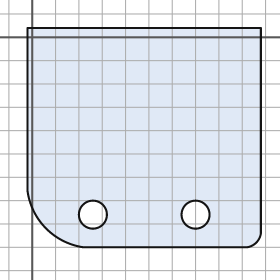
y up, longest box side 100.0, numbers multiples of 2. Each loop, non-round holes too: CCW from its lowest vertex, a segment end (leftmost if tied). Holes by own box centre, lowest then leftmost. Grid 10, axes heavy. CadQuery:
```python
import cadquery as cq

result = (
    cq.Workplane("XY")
    .moveTo(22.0, -90.0)
    .lineTo(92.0, -90.0)
    .threePointArc((96.0, -88.0), (98.0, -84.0))
    .lineTo(98.0, 4.0)
    .lineTo(-2.0, 4.0)
    .lineTo(-2.0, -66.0)
    .threePointArc((6.0, -82.0), (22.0, -90.0))
    .close()
    .moveTo(26.0, -76.0)
    .circle(6.0)
    .moveTo(70.0, -76.0)
    .circle(6.0)
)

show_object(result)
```